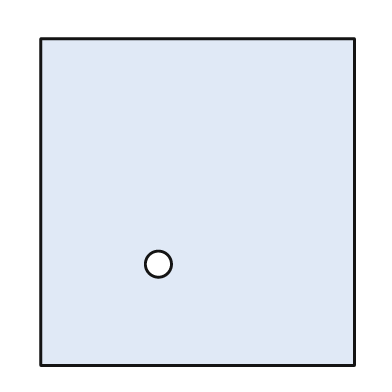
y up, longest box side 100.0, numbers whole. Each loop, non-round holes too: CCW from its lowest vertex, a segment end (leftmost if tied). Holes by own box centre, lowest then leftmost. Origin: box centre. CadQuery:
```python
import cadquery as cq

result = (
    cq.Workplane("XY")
    .moveTo(-48.0, -50.0)
    .lineTo(48.0, -50.0)
    .lineTo(48.0, 50.0)
    .lineTo(-48.0, 50.0)
    .close()
    .moveTo(-12.0, -19.0)
    .circle(4.0)
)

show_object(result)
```